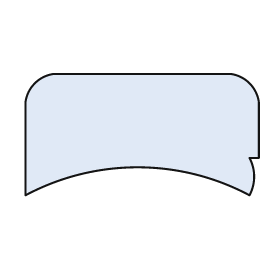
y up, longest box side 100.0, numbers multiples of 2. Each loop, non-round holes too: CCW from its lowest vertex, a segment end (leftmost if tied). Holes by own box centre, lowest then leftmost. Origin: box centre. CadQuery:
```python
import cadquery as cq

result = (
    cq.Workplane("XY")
    .moveTo(-50.0, -26.0)
    .threePointArc((-2.0, -14.0), (46.0, -26.0))
    .threePointArc((48.0, -18.0), (46.0, -10.0))
    .lineTo(50.0, -10.0)
    .lineTo(50.0, 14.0)
    .threePointArc((46.0, 22.0), (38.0, 26.0))
    .lineTo(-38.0, 26.0)
    .threePointArc((-46.0, 22.0), (-50.0, 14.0))
    .close()
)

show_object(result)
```